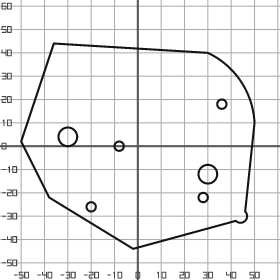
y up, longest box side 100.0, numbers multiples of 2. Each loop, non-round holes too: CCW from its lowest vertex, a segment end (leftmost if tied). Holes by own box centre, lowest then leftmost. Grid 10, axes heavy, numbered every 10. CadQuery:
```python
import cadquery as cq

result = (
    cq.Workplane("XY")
    .moveTo(-2.0, -44.0)
    .lineTo(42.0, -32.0)
    .threePointArc((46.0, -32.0), (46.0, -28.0))
    .lineTo(50.0, 10.0)
    .threePointArc((44.0, 28.0), (30.0, 40.0))
    .lineTo(-36.0, 44.0)
    .lineTo(-50.0, 2.0)
    .lineTo(-38.0, -22.0)
    .close()
    .moveTo(-20.0, -26.0)
    .circle(2.0)
    .moveTo(28.0, -22.0)
    .circle(2.0)
    .moveTo(30.0, -12.0)
    .circle(4.0)
    .moveTo(-8.0, 0.0)
    .circle(2.0)
    .moveTo(-30.0, 4.0)
    .circle(4.0)
    .moveTo(36.0, 18.0)
    .circle(2.0)
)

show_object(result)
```